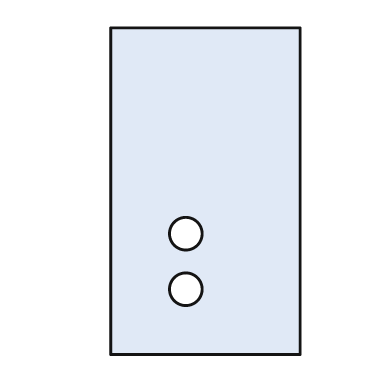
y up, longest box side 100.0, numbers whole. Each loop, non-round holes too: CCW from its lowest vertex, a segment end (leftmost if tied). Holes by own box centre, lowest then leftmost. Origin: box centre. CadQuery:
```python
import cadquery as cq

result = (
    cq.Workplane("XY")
    .moveTo(-29.0, -50.0)
    .lineTo(29.0, -50.0)
    .lineTo(29.0, 50.0)
    .lineTo(-29.0, 50.0)
    .close()
    .moveTo(-6.0, -30.0)
    .circle(5.0)
    .moveTo(-6.0, -13.0)
    .circle(5.0)
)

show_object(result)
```